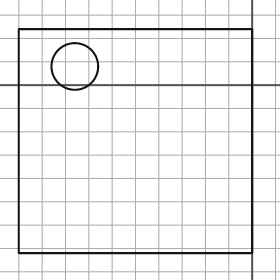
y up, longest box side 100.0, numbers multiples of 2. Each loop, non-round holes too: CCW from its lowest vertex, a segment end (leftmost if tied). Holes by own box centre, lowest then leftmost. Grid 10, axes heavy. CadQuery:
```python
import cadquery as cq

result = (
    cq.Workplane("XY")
    .moveTo(-100.0, -72.0)
    .lineTo(0.0, -72.0)
    .lineTo(0.0, 24.0)
    .lineTo(-100.0, 24.0)
    .close()
    .moveTo(-76.0, 8.0)
    .circle(10.0)
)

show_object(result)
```